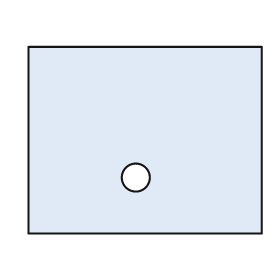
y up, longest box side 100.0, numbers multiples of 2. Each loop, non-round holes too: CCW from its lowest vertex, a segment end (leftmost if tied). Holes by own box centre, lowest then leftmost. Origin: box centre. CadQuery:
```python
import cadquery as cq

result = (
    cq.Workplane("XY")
    .moveTo(-50.0, -40.0)
    .lineTo(50.0, -40.0)
    .lineTo(50.0, 40.0)
    .lineTo(-50.0, 40.0)
    .close()
    .moveTo(-4.0, -16.0)
    .circle(6.0)
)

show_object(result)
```